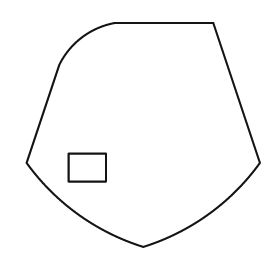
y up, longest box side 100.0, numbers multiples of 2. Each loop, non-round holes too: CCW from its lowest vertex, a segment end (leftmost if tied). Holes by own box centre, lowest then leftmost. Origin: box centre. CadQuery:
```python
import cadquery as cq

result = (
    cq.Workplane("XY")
    .moveTo(0.0, -48.0)
    .threePointArc((28.0, -34.0), (50.0, -12.0))
    .lineTo(30.0, 48.0)
    .lineTo(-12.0, 48.0)
    .threePointArc((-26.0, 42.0), (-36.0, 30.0))
    .lineTo(-50.0, -12.0)
    .threePointArc((-28.0, -34.0), (0.0, -48.0))
    .close()
    .moveTo(-32.0, -20.0)
    .lineTo(-16.0, -20.0)
    .lineTo(-16.0, -8.0)
    .lineTo(-32.0, -8.0)
    .close()
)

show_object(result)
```